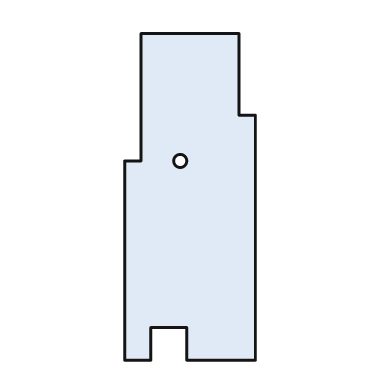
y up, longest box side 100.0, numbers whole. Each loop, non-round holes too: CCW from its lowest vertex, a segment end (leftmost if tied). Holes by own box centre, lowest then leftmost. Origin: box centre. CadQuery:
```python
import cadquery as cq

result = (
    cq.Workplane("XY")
    .moveTo(-20.0, -50.0)
    .lineTo(-12.0, -50.0)
    .lineTo(-12.0, -40.0)
    .lineTo(-1.0, -40.0)
    .lineTo(-1.0, -50.0)
    .lineTo(20.0, -50.0)
    .lineTo(20.0, 25.0)
    .lineTo(15.0, 25.0)
    .lineTo(15.0, 50.0)
    .lineTo(-15.0, 50.0)
    .lineTo(-15.0, 11.0)
    .lineTo(-20.0, 11.0)
    .close()
    .moveTo(-3.0, 11.0)
    .circle(2.0)
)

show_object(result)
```